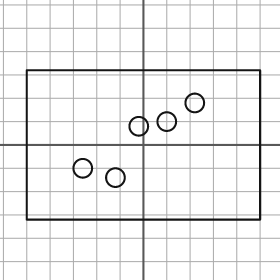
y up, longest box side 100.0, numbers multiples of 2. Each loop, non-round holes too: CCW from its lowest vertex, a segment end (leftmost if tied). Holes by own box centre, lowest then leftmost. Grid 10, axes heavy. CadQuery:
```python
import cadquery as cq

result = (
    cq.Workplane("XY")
    .moveTo(-50.0, -32.0)
    .lineTo(50.0, -32.0)
    .lineTo(50.0, 32.0)
    .lineTo(-50.0, 32.0)
    .close()
    .moveTo(-12.0, -14.0)
    .circle(4.0)
    .moveTo(-26.0, -10.0)
    .circle(4.0)
    .moveTo(-2.0, 8.0)
    .circle(4.0)
    .moveTo(10.0, 10.0)
    .circle(4.0)
    .moveTo(22.0, 18.0)
    .circle(4.0)
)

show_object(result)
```